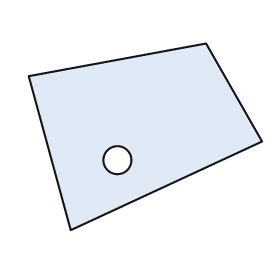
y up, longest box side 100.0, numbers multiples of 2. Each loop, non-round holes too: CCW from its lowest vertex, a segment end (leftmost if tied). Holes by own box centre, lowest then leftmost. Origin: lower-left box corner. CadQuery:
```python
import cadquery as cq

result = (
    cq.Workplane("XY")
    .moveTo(18.0, 0.0)
    .lineTo(100.0, 38.0)
    .lineTo(76.0, 80.0)
    .lineTo(0.0, 66.0)
    .close()
    .moveTo(38.0, 30.0)
    .circle(6.0)
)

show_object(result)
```